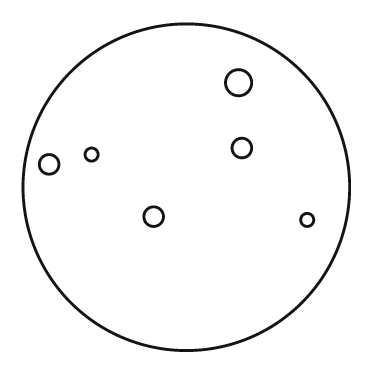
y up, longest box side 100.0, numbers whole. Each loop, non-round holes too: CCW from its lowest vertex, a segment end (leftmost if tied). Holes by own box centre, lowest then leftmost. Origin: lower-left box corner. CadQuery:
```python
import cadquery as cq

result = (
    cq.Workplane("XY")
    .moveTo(50.0, 50.0)
    .circle(50.0)
    .moveTo(87.0, 40.0)
    .circle(2.0)
    .moveTo(40.0, 41.0)
    .circle(3.0)
    .moveTo(8.0, 57.0)
    .circle(3.0)
    .moveTo(21.0, 60.0)
    .circle(2.0)
    .moveTo(67.0, 62.0)
    .circle(3.0)
    .moveTo(66.0, 82.0)
    .circle(4.0)
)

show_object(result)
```